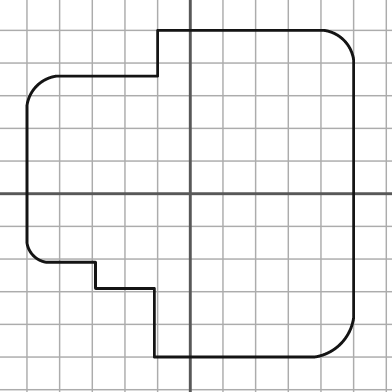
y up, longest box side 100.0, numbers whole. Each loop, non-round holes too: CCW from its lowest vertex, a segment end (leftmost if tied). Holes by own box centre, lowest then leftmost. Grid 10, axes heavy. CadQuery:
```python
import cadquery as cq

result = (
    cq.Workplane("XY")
    .moveTo(-11.0, -50.0)
    .lineTo(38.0, -50.0)
    .threePointArc((46.0, -46.0), (50.0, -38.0))
    .lineTo(50.0, 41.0)
    .threePointArc((47.0, 47.0), (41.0, 50.0))
    .lineTo(-10.0, 50.0)
    .lineTo(-10.0, 36.0)
    .lineTo(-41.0, 36.0)
    .threePointArc((-47.0, 33.0), (-50.0, 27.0))
    .lineTo(-50.0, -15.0)
    .threePointArc((-48.0, -19.0), (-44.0, -21.0))
    .lineTo(-29.0, -21.0)
    .lineTo(-29.0, -29.0)
    .lineTo(-11.0, -29.0)
    .close()
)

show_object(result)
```